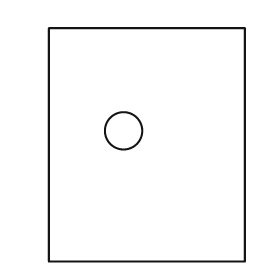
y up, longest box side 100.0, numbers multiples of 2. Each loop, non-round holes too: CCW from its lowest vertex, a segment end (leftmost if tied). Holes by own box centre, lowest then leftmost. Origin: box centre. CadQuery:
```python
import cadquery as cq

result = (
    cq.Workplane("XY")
    .moveTo(-42.0, -50.0)
    .lineTo(42.0, -50.0)
    .lineTo(42.0, 50.0)
    .lineTo(-42.0, 50.0)
    .close()
    .moveTo(-10.0, 6.0)
    .circle(8.0)
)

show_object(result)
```